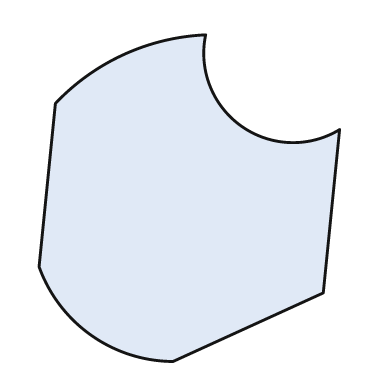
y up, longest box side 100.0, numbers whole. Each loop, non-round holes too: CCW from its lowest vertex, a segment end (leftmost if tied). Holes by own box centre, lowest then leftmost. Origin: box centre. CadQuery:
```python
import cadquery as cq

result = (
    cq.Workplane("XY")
    .moveTo(-5.0, -50.0)
    .lineTo(41.0, -29.0)
    .lineTo(46.0, 21.0)
    .threePointArc((16.0, 22.0), (5.0, 50.0))
    .threePointArc((-20.0, 44.0), (-41.0, 29.0))
    .lineTo(-46.0, -21.0)
    .threePointArc((-30.0, -42.0), (-5.0, -50.0))
    .close()
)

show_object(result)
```